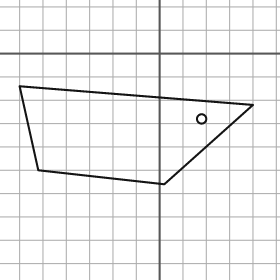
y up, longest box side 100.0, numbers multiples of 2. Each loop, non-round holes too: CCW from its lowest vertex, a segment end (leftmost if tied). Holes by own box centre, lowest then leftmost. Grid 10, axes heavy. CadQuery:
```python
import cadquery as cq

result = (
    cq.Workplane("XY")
    .moveTo(2.0, -56.0)
    .lineTo(40.0, -22.0)
    .lineTo(-60.0, -14.0)
    .lineTo(-52.0, -50.0)
    .close()
    .moveTo(18.0, -28.0)
    .circle(2.0)
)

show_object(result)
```